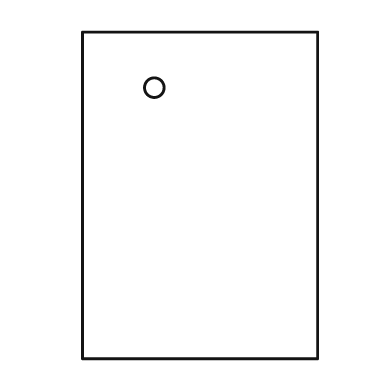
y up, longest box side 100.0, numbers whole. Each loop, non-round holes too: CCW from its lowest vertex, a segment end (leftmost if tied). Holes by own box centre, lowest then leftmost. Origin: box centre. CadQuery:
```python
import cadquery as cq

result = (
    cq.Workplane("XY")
    .moveTo(-36.0, -50.0)
    .lineTo(36.0, -50.0)
    .lineTo(36.0, 50.0)
    .lineTo(-36.0, 50.0)
    .close()
    .moveTo(-14.0, 33.0)
    .circle(3.0)
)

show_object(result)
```